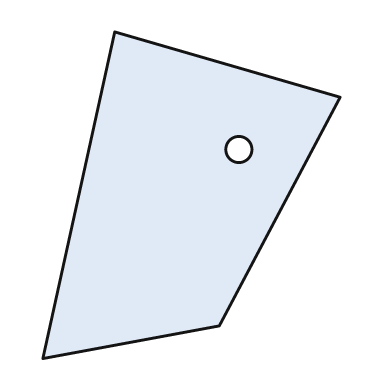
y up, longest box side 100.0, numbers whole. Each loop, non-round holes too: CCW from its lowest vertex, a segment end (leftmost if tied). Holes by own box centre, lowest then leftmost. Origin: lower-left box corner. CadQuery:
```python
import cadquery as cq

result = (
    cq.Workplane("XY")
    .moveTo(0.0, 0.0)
    .lineTo(54.0, 10.0)
    .lineTo(91.0, 80.0)
    .lineTo(22.0, 100.0)
    .close()
    .moveTo(60.0, 64.0)
    .circle(4.0)
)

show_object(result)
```